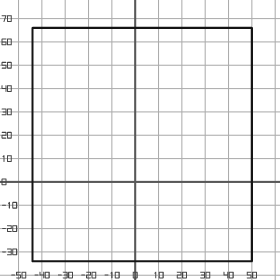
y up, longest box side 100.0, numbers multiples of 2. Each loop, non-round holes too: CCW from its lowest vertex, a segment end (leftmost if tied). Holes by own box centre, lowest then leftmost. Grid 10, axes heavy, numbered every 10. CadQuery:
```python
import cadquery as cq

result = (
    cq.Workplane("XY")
    .moveTo(-44.0, -34.0)
    .lineTo(50.0, -34.0)
    .lineTo(50.0, 66.0)
    .lineTo(-44.0, 66.0)
    .close()
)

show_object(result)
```